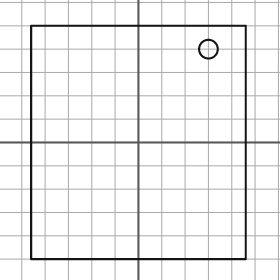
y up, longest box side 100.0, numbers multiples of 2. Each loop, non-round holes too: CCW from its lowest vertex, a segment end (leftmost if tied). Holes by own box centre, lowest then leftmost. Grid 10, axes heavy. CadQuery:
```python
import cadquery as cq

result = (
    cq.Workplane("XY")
    .moveTo(-46.0, -50.0)
    .lineTo(46.0, -50.0)
    .lineTo(46.0, 50.0)
    .lineTo(-46.0, 50.0)
    .close()
    .moveTo(30.0, 40.0)
    .circle(4.0)
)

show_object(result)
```